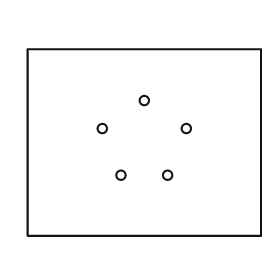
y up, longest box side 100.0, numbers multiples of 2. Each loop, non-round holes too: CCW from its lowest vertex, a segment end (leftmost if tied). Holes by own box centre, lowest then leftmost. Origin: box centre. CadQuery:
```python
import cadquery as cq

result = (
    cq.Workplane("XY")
    .moveTo(-50.0, -40.0)
    .lineTo(50.0, -40.0)
    .lineTo(50.0, 40.0)
    .lineTo(-50.0, 40.0)
    .close()
    .moveTo(-10.0, -14.0)
    .circle(2.0)
    .moveTo(10.0, -14.0)
    .circle(2.0)
    .moveTo(-18.0, 6.0)
    .circle(2.0)
    .moveTo(18.0, 6.0)
    .circle(2.0)
    .moveTo(0.0, 18.0)
    .circle(2.0)
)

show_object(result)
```